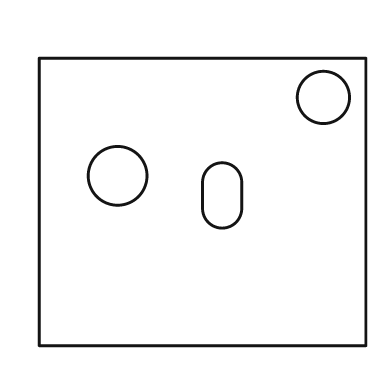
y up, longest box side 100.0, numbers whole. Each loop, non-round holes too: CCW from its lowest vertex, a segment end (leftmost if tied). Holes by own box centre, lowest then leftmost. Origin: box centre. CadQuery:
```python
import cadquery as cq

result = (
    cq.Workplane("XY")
    .moveTo(-50.0, -44.0)
    .lineTo(50.0, -44.0)
    .lineTo(50.0, 44.0)
    .lineTo(-50.0, 44.0)
    .close()
    .moveTo(0.0, -2.0)
    .threePointArc((6.0, -8.0), (12.0, -2.0))
    .lineTo(12.0, 6.0)
    .threePointArc((6.0, 12.0), (0.0, 6.0))
    .close()
    .moveTo(-26.0, 8.0)
    .circle(9.0)
    .moveTo(37.0, 32.0)
    .circle(8.0)
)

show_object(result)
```